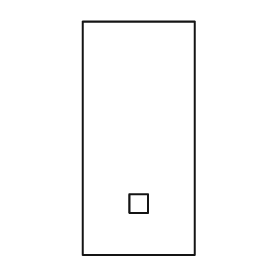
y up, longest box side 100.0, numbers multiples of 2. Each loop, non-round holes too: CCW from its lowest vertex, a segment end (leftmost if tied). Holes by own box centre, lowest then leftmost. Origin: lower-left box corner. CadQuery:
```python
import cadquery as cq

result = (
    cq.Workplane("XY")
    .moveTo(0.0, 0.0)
    .lineTo(48.0, 0.0)
    .lineTo(48.0, 100.0)
    .lineTo(0.0, 100.0)
    .close()
    .moveTo(20.0, 18.0)
    .lineTo(28.0, 18.0)
    .lineTo(28.0, 26.0)
    .lineTo(20.0, 26.0)
    .close()
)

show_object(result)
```